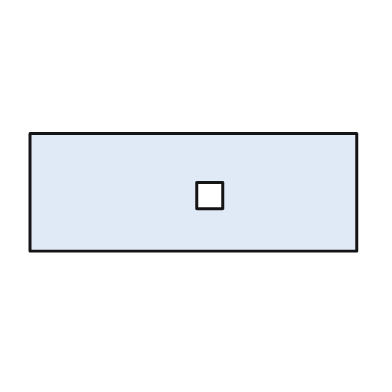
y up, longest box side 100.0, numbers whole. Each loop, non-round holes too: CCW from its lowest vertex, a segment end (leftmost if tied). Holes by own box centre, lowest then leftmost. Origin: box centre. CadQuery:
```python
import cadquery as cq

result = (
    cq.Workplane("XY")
    .moveTo(-50.0, -18.0)
    .lineTo(50.0, -18.0)
    .lineTo(50.0, 18.0)
    .lineTo(-50.0, 18.0)
    .close()
    .moveTo(1.0, -5.0)
    .lineTo(9.0, -5.0)
    .lineTo(9.0, 3.0)
    .lineTo(1.0, 3.0)
    .close()
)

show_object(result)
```